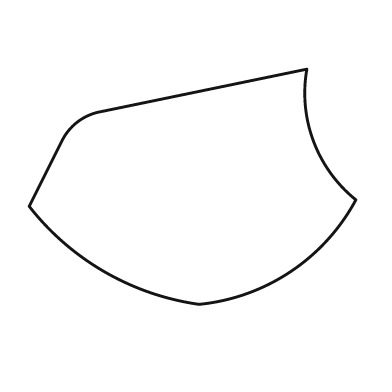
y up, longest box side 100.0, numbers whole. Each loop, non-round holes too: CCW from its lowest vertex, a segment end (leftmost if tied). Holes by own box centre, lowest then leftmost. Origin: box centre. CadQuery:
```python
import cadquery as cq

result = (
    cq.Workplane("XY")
    .moveTo(2.0, -36.0)
    .threePointArc((30.0, -26.0), (50.0, -4.0))
    .threePointArc((37.0, 14.0), (35.0, 36.0))
    .lineTo(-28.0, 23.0)
    .threePointArc((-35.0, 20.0), (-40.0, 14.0))
    .lineTo(-50.0, -6.0)
    .threePointArc((-27.0, -26.0), (2.0, -36.0))
    .close()
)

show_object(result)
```